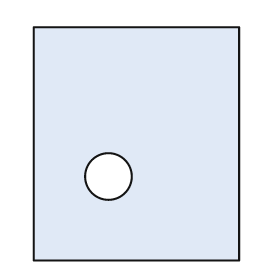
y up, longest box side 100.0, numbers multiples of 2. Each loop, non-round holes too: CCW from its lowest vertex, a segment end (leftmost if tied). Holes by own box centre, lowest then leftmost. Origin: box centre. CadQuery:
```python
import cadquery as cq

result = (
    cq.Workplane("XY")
    .moveTo(-44.0, -50.0)
    .lineTo(44.0, -50.0)
    .lineTo(44.0, 50.0)
    .lineTo(-44.0, 50.0)
    .close()
    .moveTo(-12.0, -14.0)
    .circle(10.0)
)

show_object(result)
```